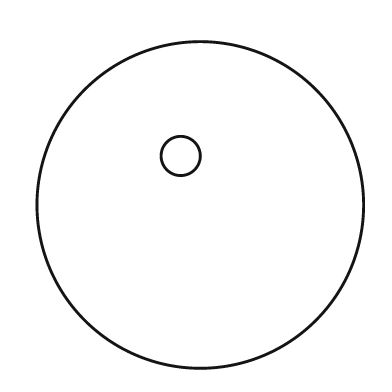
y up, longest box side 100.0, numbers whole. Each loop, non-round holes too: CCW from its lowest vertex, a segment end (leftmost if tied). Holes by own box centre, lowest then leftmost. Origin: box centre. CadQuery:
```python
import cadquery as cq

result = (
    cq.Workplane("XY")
    .moveTo(0.0, 0.0)
    .circle(50.0)
    .moveTo(-6.0, 15.0)
    .circle(6.0)
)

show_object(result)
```